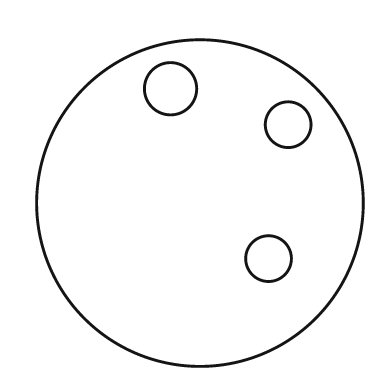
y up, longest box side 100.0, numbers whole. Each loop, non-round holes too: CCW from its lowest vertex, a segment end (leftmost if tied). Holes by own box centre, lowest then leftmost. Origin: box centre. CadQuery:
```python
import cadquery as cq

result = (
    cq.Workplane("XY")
    .moveTo(0.0, 0.0)
    .circle(50.0)
    .moveTo(21.0, -17.0)
    .circle(7.0)
    .moveTo(27.0, 24.0)
    .circle(7.0)
    .moveTo(-9.0, 35.0)
    .circle(8.0)
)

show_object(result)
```